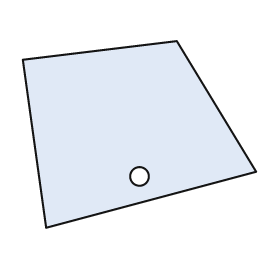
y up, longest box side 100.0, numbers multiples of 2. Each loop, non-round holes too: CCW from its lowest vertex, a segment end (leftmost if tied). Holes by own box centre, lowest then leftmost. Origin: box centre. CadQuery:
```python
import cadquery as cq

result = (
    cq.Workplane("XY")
    .moveTo(-40.0, -40.0)
    .lineTo(50.0, -16.0)
    .lineTo(16.0, 40.0)
    .lineTo(-50.0, 32.0)
    .close()
    .moveTo(0.0, -18.0)
    .circle(4.0)
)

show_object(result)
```